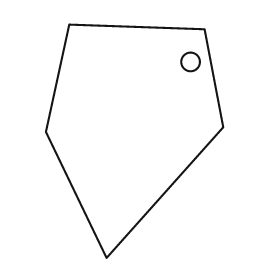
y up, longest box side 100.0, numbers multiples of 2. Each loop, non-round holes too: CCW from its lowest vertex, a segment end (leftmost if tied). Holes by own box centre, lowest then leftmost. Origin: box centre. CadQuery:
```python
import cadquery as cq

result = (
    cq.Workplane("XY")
    .moveTo(-12.0, -50.0)
    .lineTo(38.0, 6.0)
    .lineTo(30.0, 48.0)
    .lineTo(-28.0, 50.0)
    .lineTo(-38.0, 4.0)
    .close()
    .moveTo(24.0, 34.0)
    .circle(4.0)
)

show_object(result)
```